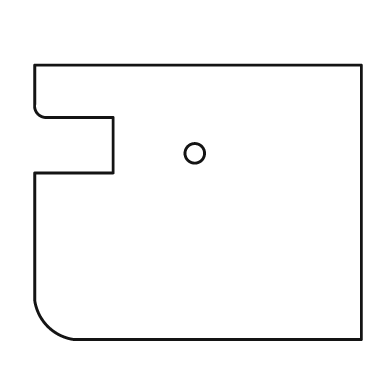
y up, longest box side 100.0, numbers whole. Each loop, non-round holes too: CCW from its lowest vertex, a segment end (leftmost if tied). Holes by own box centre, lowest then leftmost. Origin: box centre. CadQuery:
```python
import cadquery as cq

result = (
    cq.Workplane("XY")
    .moveTo(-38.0, -42.0)
    .lineTo(50.0, -42.0)
    .lineTo(50.0, 42.0)
    .lineTo(-50.0, 42.0)
    .lineTo(-50.0, 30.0)
    .threePointArc((-49.0, 27.0), (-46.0, 26.0))
    .lineTo(-26.0, 26.0)
    .lineTo(-26.0, 9.0)
    .lineTo(-50.0, 9.0)
    .lineTo(-50.0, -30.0)
    .threePointArc((-46.0, -38.0), (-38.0, -42.0))
    .close()
    .moveTo(-1.0, 15.0)
    .circle(3.0)
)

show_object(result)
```